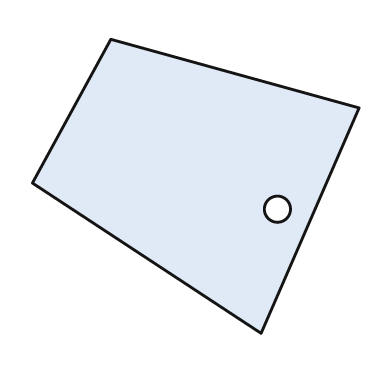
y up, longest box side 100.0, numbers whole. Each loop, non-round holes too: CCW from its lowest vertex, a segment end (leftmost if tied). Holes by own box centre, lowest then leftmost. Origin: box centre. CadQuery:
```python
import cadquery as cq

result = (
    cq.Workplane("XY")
    .moveTo(20.0, -45.0)
    .lineTo(50.0, 24.0)
    .lineTo(-26.0, 45.0)
    .lineTo(-50.0, 1.0)
    .close()
    .moveTo(25.0, -7.0)
    .circle(4.0)
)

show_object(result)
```